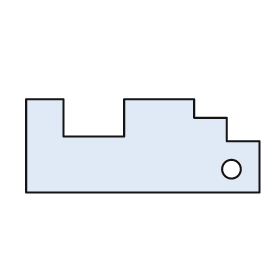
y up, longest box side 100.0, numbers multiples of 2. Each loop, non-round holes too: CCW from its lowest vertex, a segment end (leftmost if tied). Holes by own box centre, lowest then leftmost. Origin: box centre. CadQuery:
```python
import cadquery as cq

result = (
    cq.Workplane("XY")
    .moveTo(-50.0, -20.0)
    .lineTo(50.0, -20.0)
    .lineTo(50.0, 2.0)
    .lineTo(36.0, 2.0)
    .lineTo(36.0, 12.0)
    .lineTo(22.0, 12.0)
    .lineTo(22.0, 20.0)
    .lineTo(-8.0, 20.0)
    .lineTo(-8.0, 4.0)
    .lineTo(-34.0, 4.0)
    .lineTo(-34.0, 20.0)
    .lineTo(-50.0, 20.0)
    .close()
    .moveTo(38.0, -10.0)
    .circle(4.0)
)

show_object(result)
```